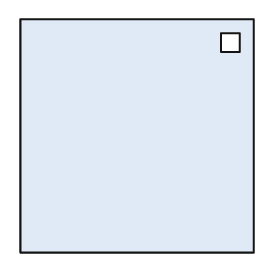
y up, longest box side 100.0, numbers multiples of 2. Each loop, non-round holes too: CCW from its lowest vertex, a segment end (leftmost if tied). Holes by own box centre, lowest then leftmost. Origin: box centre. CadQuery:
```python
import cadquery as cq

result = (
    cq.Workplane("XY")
    .moveTo(-50.0, -50.0)
    .lineTo(50.0, -50.0)
    .lineTo(50.0, 50.0)
    .lineTo(-50.0, 50.0)
    .close()
    .moveTo(36.0, 36.0)
    .lineTo(44.0, 36.0)
    .lineTo(44.0, 44.0)
    .lineTo(36.0, 44.0)
    .close()
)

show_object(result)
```